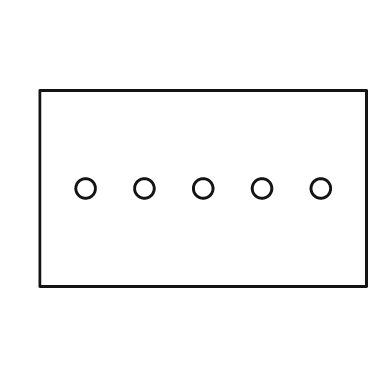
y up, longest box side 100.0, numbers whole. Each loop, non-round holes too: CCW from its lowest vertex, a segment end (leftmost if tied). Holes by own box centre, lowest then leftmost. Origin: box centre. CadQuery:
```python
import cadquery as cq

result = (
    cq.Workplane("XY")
    .moveTo(-50.0, -30.0)
    .lineTo(50.0, -30.0)
    .lineTo(50.0, 30.0)
    .lineTo(-50.0, 30.0)
    .close()
    .moveTo(-36.0, 0.0)
    .circle(3.0)
    .moveTo(-18.0, 0.0)
    .circle(3.0)
    .moveTo(0.0, 0.0)
    .circle(3.0)
    .moveTo(18.0, 0.0)
    .circle(3.0)
    .moveTo(36.0, 0.0)
    .circle(3.0)
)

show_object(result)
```